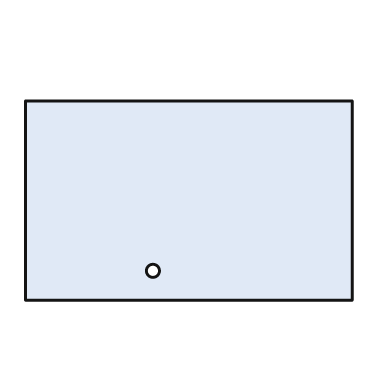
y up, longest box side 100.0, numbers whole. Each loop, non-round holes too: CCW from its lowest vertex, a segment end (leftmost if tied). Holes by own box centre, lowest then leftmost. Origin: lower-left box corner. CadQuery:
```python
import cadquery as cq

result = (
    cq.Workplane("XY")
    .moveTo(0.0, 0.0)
    .lineTo(100.0, 0.0)
    .lineTo(100.0, 61.0)
    .lineTo(0.0, 61.0)
    .close()
    .moveTo(39.0, 9.0)
    .circle(2.0)
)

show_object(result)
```